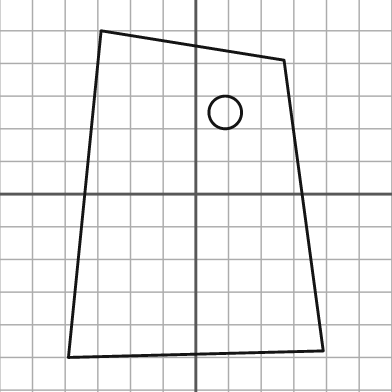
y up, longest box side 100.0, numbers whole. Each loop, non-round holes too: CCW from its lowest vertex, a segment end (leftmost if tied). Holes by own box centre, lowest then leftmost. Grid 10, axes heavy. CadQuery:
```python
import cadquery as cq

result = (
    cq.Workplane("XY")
    .moveTo(-39.0, -50.0)
    .lineTo(39.0, -48.0)
    .lineTo(27.0, 41.0)
    .lineTo(-29.0, 50.0)
    .close()
    .moveTo(9.0, 25.0)
    .circle(5.0)
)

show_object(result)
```